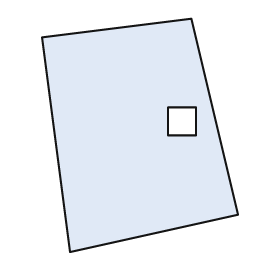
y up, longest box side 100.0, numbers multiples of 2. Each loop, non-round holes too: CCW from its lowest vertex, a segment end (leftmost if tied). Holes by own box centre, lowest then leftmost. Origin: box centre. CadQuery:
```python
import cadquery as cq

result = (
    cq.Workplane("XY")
    .moveTo(-30.0, -50.0)
    .lineTo(42.0, -34.0)
    .lineTo(22.0, 50.0)
    .lineTo(-42.0, 42.0)
    .close()
    .moveTo(12.0, 0.0)
    .lineTo(24.0, 0.0)
    .lineTo(24.0, 12.0)
    .lineTo(12.0, 12.0)
    .close()
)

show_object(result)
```